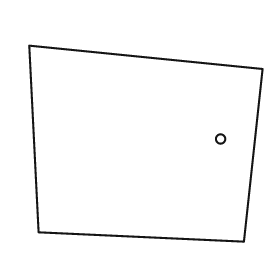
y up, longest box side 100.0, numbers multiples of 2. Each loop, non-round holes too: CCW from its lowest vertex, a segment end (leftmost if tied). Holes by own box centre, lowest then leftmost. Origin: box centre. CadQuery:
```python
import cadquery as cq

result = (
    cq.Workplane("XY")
    .moveTo(42.0, -42.0)
    .lineTo(50.0, 32.0)
    .lineTo(-50.0, 42.0)
    .lineTo(-46.0, -38.0)
    .close()
    .moveTo(32.0, 2.0)
    .circle(2.0)
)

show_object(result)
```